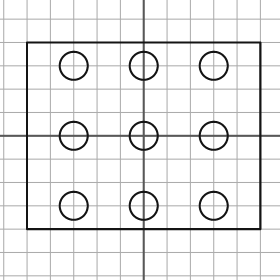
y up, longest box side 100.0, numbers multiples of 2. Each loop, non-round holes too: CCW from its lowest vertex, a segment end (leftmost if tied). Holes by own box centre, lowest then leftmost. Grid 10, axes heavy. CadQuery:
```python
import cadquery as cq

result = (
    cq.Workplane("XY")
    .moveTo(-50.0, -40.0)
    .lineTo(50.0, -40.0)
    .lineTo(50.0, 40.0)
    .lineTo(-50.0, 40.0)
    .close()
    .moveTo(-30.0, -30.0)
    .circle(6.0)
    .moveTo(0.0, -30.0)
    .circle(6.0)
    .moveTo(30.0, -30.0)
    .circle(6.0)
    .moveTo(-30.0, 0.0)
    .circle(6.0)
    .moveTo(0.0, 0.0)
    .circle(6.0)
    .moveTo(30.0, 0.0)
    .circle(6.0)
    .moveTo(-30.0, 30.0)
    .circle(6.0)
    .moveTo(0.0, 30.0)
    .circle(6.0)
    .moveTo(30.0, 30.0)
    .circle(6.0)
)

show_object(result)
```